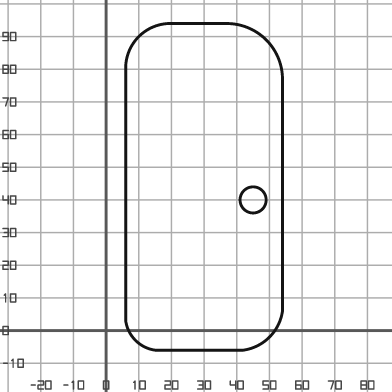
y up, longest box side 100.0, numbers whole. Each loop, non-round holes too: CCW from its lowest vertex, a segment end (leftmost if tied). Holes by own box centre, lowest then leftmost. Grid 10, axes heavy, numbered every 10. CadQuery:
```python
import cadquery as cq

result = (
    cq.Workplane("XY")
    .moveTo(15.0, -6.0)
    .lineTo(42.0, -6.0)
    .threePointArc((50.0, -2.0), (54.0, 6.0))
    .lineTo(54.0, 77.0)
    .threePointArc((49.0, 89.0), (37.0, 94.0))
    .lineTo(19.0, 94.0)
    .threePointArc((10.0, 90.0), (6.0, 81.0))
    .lineTo(6.0, 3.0)
    .threePointArc((9.0, -3.0), (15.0, -6.0))
    .close()
    .moveTo(45.0, 40.0)
    .circle(4.0)
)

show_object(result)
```